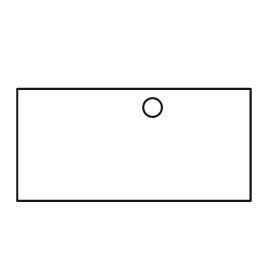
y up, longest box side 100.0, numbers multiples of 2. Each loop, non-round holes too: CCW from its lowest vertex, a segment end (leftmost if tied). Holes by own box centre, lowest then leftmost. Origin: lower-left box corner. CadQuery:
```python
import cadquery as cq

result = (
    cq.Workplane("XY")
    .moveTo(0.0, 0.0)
    .lineTo(100.0, 0.0)
    .lineTo(100.0, 48.0)
    .lineTo(0.0, 48.0)
    .close()
    .moveTo(58.0, 40.0)
    .circle(4.0)
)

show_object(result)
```